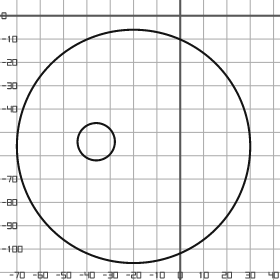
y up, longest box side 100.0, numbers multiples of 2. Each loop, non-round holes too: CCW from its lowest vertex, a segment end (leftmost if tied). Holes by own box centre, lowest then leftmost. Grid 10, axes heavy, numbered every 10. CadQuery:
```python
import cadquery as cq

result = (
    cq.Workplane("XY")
    .moveTo(-20.0, -56.0)
    .circle(50.0)
    .moveTo(-36.0, -54.0)
    .circle(8.0)
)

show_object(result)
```